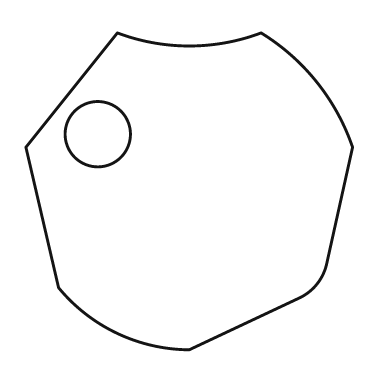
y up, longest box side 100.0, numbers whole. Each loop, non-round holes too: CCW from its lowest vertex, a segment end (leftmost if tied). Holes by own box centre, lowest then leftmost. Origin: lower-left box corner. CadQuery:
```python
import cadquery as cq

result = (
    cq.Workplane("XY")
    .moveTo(50.0, 0.0)
    .lineTo(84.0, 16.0)
    .threePointArc((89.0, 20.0), (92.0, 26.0))
    .lineTo(100.0, 62.0)
    .threePointArc((89.0, 82.0), (72.0, 97.0))
    .threePointArc((50.0, 93.0), (28.0, 97.0))
    .lineTo(0.0, 62.0)
    .lineTo(10.0, 19.0)
    .threePointArc((28.0, 5.0), (50.0, 0.0))
    .close()
    .moveTo(22.0, 66.0)
    .circle(10.0)
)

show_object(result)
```